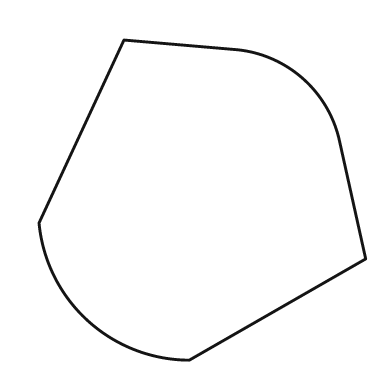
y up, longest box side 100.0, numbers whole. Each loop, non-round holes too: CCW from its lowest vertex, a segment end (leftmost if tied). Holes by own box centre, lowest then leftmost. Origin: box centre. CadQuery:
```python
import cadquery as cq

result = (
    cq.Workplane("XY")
    .moveTo(-4.0, -49.0)
    .lineTo(50.0, -18.0)
    .lineTo(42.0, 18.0)
    .threePointArc((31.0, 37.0), (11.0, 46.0))
    .lineTo(-24.0, 49.0)
    .lineTo(-50.0, -7.0)
    .threePointArc((-35.0, -37.0), (-4.0, -49.0))
    .close()
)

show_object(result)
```